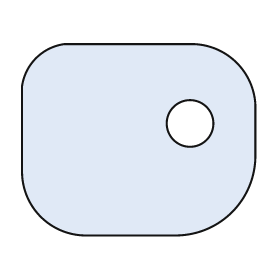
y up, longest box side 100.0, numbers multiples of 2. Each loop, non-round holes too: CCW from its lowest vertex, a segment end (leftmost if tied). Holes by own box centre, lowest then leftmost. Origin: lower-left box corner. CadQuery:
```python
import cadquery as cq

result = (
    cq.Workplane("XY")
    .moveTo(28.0, 0.0)
    .lineTo(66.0, 0.0)
    .threePointArc((90.0, 10.0), (100.0, 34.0))
    .lineTo(100.0, 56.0)
    .threePointArc((92.0, 74.0), (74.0, 82.0))
    .lineTo(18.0, 82.0)
    .threePointArc((6.0, 76.0), (0.0, 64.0))
    .lineTo(0.0, 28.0)
    .threePointArc((8.0, 8.0), (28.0, 0.0))
    .close()
    .moveTo(72.0, 48.0)
    .circle(10.0)
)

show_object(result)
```